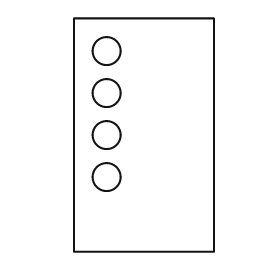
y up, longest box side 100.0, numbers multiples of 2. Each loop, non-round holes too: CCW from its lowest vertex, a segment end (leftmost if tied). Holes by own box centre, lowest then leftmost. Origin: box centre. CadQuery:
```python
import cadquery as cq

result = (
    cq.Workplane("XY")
    .moveTo(-30.0, -50.0)
    .lineTo(30.0, -50.0)
    .lineTo(30.0, 50.0)
    .lineTo(-30.0, 50.0)
    .close()
    .moveTo(-16.0, -18.0)
    .circle(6.0)
    .moveTo(-16.0, 0.0)
    .circle(6.0)
    .moveTo(-16.0, 18.0)
    .circle(6.0)
    .moveTo(-16.0, 36.0)
    .circle(6.0)
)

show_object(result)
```